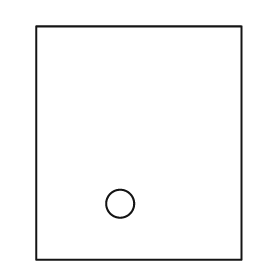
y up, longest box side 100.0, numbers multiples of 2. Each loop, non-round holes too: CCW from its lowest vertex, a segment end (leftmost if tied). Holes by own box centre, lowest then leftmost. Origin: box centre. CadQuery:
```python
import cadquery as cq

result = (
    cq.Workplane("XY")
    .moveTo(-44.0, -50.0)
    .lineTo(44.0, -50.0)
    .lineTo(44.0, 50.0)
    .lineTo(-44.0, 50.0)
    .close()
    .moveTo(-8.0, -26.0)
    .circle(6.0)
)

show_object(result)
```